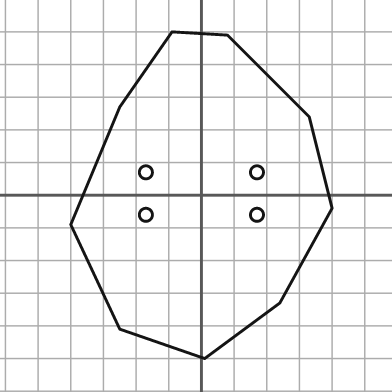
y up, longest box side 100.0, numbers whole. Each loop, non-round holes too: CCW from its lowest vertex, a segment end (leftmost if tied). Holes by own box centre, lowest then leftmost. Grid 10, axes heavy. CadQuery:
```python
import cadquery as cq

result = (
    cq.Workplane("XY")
    .moveTo(1.0, -50.0)
    .lineTo(24.0, -33.0)
    .lineTo(40.0, -4.0)
    .lineTo(33.0, 24.0)
    .lineTo(8.0, 49.0)
    .lineTo(-9.0, 50.0)
    .lineTo(-25.0, 27.0)
    .lineTo(-40.0, -9.0)
    .lineTo(-25.0, -41.0)
    .close()
    .moveTo(-17.0, -6.0)
    .circle(2.0)
    .moveTo(17.0, -6.0)
    .circle(2.0)
    .moveTo(-17.0, 7.0)
    .circle(2.0)
    .moveTo(17.0, 7.0)
    .circle(2.0)
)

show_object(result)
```